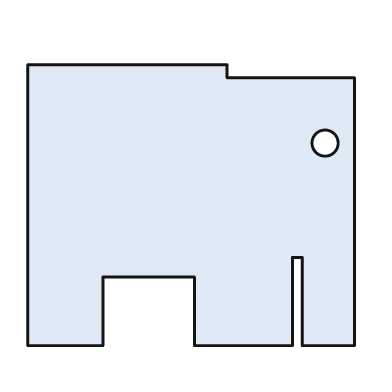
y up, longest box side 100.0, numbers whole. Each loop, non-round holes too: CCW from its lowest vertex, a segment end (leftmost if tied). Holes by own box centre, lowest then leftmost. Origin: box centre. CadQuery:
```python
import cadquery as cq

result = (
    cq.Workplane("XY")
    .moveTo(-50.0, -43.0)
    .lineTo(-27.0, -43.0)
    .lineTo(-27.0, -22.0)
    .lineTo(1.0, -22.0)
    .lineTo(1.0, -43.0)
    .lineTo(31.0, -43.0)
    .lineTo(31.0, -16.0)
    .lineTo(34.0, -16.0)
    .lineTo(34.0, -43.0)
    .lineTo(50.0, -43.0)
    .lineTo(50.0, 39.0)
    .lineTo(11.0, 39.0)
    .lineTo(11.0, 43.0)
    .lineTo(-50.0, 43.0)
    .close()
    .moveTo(41.0, 19.0)
    .circle(4.0)
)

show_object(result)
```